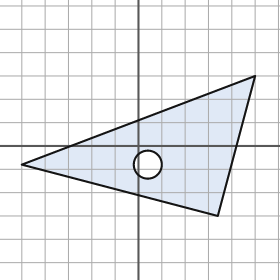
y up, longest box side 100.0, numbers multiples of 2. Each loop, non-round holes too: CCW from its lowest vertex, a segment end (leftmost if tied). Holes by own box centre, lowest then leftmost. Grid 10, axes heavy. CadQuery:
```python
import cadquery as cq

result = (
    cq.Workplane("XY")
    .moveTo(34.0, -30.0)
    .lineTo(50.0, 30.0)
    .lineTo(-50.0, -8.0)
    .close()
    .moveTo(4.0, -8.0)
    .circle(6.0)
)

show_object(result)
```